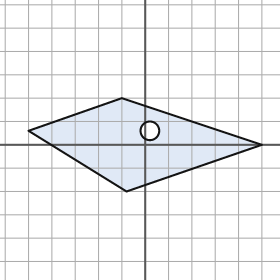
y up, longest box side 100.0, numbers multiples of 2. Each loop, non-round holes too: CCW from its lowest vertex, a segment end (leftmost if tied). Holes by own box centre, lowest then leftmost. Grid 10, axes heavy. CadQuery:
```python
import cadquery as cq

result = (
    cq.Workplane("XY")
    .moveTo(-8.0, -20.0)
    .lineTo(50.0, 0.0)
    .lineTo(-10.0, 20.0)
    .lineTo(-50.0, 6.0)
    .close()
    .moveTo(2.0, 6.0)
    .circle(4.0)
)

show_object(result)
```